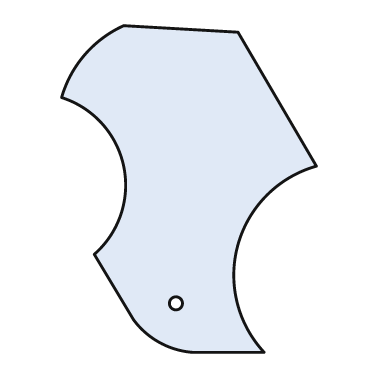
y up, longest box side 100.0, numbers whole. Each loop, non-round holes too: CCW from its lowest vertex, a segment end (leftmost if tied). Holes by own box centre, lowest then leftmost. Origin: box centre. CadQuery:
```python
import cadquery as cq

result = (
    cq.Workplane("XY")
    .moveTo(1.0, -50.0)
    .lineTo(23.0, -50.0)
    .threePointArc((15.0, -17.0), (39.0, 7.0))
    .lineTo(15.0, 48.0)
    .lineTo(-20.0, 50.0)
    .threePointArc((-32.0, 41.0), (-39.0, 28.0))
    .threePointArc((-20.0, 7.0), (-29.0, -20.0))
    .lineTo(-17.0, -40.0)
    .threePointArc((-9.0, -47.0), (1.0, -50.0))
    .close()
    .moveTo(-4.0, -35.0)
    .circle(2.0)
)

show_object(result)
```